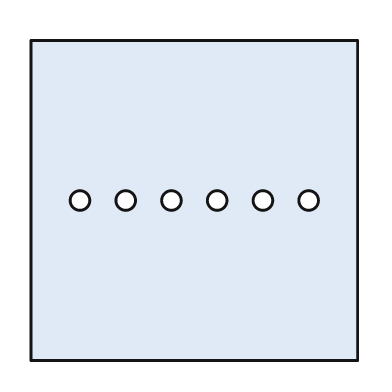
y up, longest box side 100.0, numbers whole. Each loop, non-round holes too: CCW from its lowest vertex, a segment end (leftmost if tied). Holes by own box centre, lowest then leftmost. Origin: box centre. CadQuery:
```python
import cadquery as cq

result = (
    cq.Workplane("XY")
    .moveTo(-50.0, -49.0)
    .lineTo(50.0, -49.0)
    .lineTo(50.0, 49.0)
    .lineTo(-50.0, 49.0)
    .close()
    .moveTo(-35.0, 0.0)
    .circle(3.0)
    .moveTo(-21.0, 0.0)
    .circle(3.0)
    .moveTo(-7.0, 0.0)
    .circle(3.0)
    .moveTo(7.0, 0.0)
    .circle(3.0)
    .moveTo(21.0, 0.0)
    .circle(3.0)
    .moveTo(35.0, 0.0)
    .circle(3.0)
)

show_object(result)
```